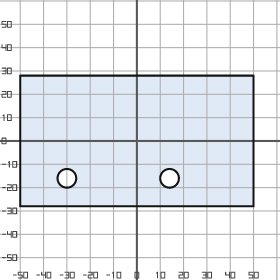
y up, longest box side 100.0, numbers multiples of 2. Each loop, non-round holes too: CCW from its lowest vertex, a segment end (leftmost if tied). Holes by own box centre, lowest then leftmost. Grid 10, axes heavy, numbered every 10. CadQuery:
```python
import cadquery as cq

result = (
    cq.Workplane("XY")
    .moveTo(-50.0, -28.0)
    .lineTo(50.0, -28.0)
    .lineTo(50.0, 28.0)
    .lineTo(-50.0, 28.0)
    .close()
    .moveTo(-30.0, -16.0)
    .circle(4.0)
    .moveTo(14.0, -16.0)
    .circle(4.0)
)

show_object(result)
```